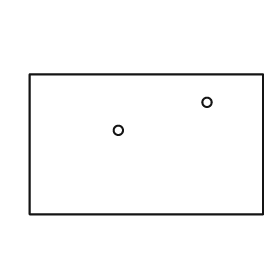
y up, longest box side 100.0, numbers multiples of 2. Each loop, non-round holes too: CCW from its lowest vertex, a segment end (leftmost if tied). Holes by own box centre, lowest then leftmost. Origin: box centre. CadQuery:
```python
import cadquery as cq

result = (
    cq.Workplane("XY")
    .moveTo(-50.0, -30.0)
    .lineTo(50.0, -30.0)
    .lineTo(50.0, 30.0)
    .lineTo(-50.0, 30.0)
    .close()
    .moveTo(-12.0, 6.0)
    .circle(2.0)
    .moveTo(26.0, 18.0)
    .circle(2.0)
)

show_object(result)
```